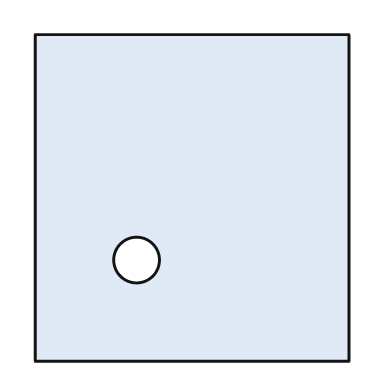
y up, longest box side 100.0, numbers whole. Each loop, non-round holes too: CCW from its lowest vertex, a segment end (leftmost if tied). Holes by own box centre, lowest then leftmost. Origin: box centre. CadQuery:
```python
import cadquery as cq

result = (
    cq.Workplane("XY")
    .moveTo(-48.0, -50.0)
    .lineTo(48.0, -50.0)
    .lineTo(48.0, 50.0)
    .lineTo(-48.0, 50.0)
    .close()
    .moveTo(-17.0, -19.0)
    .circle(7.0)
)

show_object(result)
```